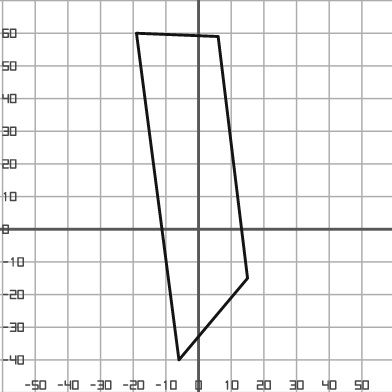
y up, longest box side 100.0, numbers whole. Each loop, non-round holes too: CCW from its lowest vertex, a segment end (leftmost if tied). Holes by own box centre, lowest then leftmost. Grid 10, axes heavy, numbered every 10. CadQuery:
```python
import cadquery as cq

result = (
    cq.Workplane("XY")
    .moveTo(-6.0, -40.0)
    .lineTo(15.0, -15.0)
    .lineTo(6.0, 59.0)
    .lineTo(-19.0, 60.0)
    .close()
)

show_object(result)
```